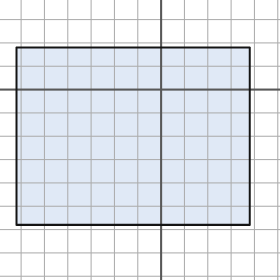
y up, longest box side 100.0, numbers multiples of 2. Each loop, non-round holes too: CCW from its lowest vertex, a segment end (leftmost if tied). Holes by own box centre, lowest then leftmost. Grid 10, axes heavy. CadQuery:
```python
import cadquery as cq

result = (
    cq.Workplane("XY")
    .moveTo(-62.0, -58.0)
    .lineTo(38.0, -58.0)
    .lineTo(38.0, 18.0)
    .lineTo(-62.0, 18.0)
    .close()
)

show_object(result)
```